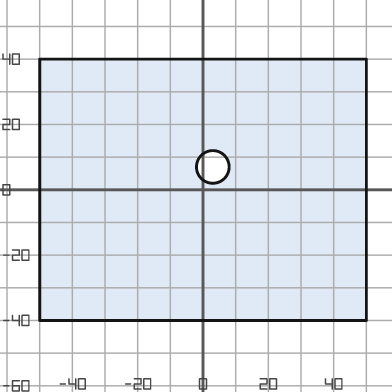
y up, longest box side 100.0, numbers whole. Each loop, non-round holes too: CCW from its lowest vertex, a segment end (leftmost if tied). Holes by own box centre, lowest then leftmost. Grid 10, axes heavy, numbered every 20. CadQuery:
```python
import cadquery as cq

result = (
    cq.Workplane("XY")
    .moveTo(-50.0, -40.0)
    .lineTo(50.0, -40.0)
    .lineTo(50.0, 40.0)
    .lineTo(-50.0, 40.0)
    .close()
    .moveTo(3.0, 7.0)
    .circle(5.0)
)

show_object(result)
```